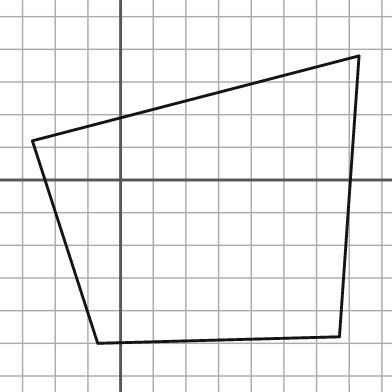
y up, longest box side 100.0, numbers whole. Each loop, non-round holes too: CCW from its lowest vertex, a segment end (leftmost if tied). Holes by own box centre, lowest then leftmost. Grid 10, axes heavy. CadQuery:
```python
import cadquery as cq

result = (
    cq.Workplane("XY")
    .moveTo(-7.0, -50.0)
    .lineTo(67.0, -48.0)
    .lineTo(73.0, 38.0)
    .lineTo(-27.0, 12.0)
    .close()
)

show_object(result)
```